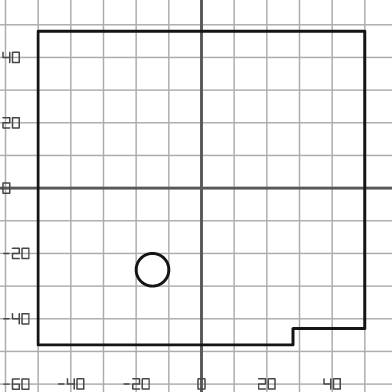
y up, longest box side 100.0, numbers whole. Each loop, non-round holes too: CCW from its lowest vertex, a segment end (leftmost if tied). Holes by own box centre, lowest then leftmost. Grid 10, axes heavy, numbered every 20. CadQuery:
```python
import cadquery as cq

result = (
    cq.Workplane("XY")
    .moveTo(-50.0, -48.0)
    .lineTo(28.0, -48.0)
    .lineTo(28.0, -43.0)
    .lineTo(50.0, -43.0)
    .lineTo(50.0, 48.0)
    .lineTo(-50.0, 48.0)
    .close()
    .moveTo(-15.0, -25.0)
    .circle(5.0)
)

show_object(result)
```